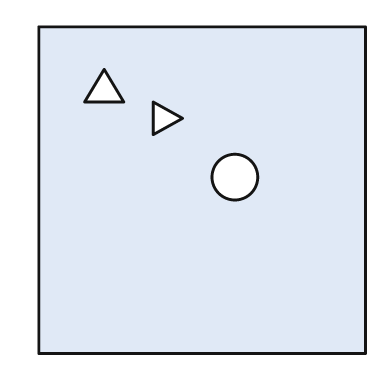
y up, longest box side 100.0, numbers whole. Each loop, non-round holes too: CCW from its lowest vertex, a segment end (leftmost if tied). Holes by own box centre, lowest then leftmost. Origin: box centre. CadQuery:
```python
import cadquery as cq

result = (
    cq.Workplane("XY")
    .moveTo(-50.0, -50.0)
    .lineTo(50.0, -50.0)
    .lineTo(50.0, 50.0)
    .lineTo(-50.0, 50.0)
    .close()
    .moveTo(10.0, 4.0)
    .circle(7.0)
    .moveTo(-15.0, 17.0)
    .lineTo(-6.0, 22.0)
    .lineTo(-15.0, 27.0)
    .close()
    .moveTo(-36.0, 27.0)
    .lineTo(-24.0, 27.0)
    .lineTo(-30.0, 37.0)
    .close()
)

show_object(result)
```